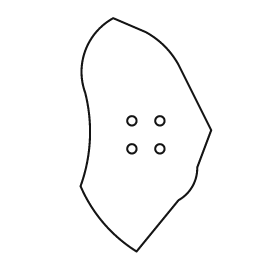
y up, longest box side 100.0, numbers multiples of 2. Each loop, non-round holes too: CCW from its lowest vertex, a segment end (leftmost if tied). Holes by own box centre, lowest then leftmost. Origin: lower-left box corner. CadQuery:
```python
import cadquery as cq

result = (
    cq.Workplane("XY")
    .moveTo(24.0, 0.0)
    .lineTo(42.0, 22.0)
    .threePointArc((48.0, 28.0), (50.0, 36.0))
    .lineTo(56.0, 52.0)
    .lineTo(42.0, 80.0)
    .threePointArc((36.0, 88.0), (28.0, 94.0))
    .lineTo(14.0, 100.0)
    .threePointArc((2.0, 86.0), (2.0, 68.0))
    .threePointArc((4.0, 48.0), (0.0, 28.0))
    .threePointArc((10.0, 12.0), (24.0, 0.0))
    .close()
    .moveTo(22.0, 44.0)
    .circle(2.0)
    .moveTo(34.0, 44.0)
    .circle(2.0)
    .moveTo(22.0, 56.0)
    .circle(2.0)
    .moveTo(34.0, 56.0)
    .circle(2.0)
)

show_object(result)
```